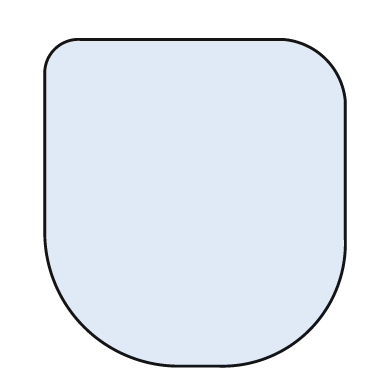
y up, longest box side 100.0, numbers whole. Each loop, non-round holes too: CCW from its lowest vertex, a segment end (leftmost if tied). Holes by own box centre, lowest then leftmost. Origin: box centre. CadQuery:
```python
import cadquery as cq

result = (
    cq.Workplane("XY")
    .moveTo(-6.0, -50.0)
    .lineTo(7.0, -50.0)
    .threePointArc((35.0, -39.0), (46.0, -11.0))
    .lineTo(46.0, 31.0)
    .threePointArc((40.0, 44.0), (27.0, 50.0))
    .lineTo(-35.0, 50.0)
    .threePointArc((-43.0, 47.0), (-46.0, 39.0))
    .lineTo(-46.0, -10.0)
    .threePointArc((-34.0, -38.0), (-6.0, -50.0))
    .close()
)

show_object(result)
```